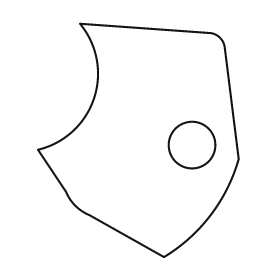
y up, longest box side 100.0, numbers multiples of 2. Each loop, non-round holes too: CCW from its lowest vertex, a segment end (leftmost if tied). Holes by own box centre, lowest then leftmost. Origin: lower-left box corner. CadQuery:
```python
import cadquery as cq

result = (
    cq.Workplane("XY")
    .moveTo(54.0, 0.0)
    .threePointArc((74.0, 18.0), (86.0, 42.0))
    .lineTo(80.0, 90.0)
    .threePointArc((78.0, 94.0), (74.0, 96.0))
    .lineTo(18.0, 100.0)
    .threePointArc((24.0, 68.0), (0.0, 46.0))
    .lineTo(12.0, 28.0)
    .threePointArc((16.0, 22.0), (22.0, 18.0))
    .close()
    .moveTo(66.0, 48.0)
    .circle(10.0)
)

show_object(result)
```